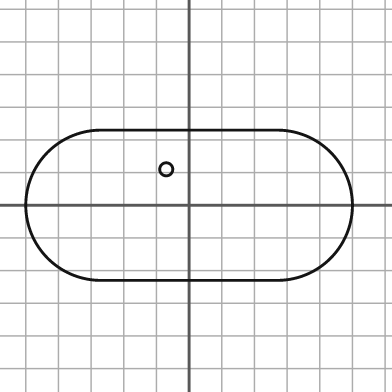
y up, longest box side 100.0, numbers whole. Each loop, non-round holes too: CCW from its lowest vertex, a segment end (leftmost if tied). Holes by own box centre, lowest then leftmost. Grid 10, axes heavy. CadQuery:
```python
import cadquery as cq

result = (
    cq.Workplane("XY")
    .moveTo(-27.0, -23.0)
    .lineTo(27.0, -23.0)
    .threePointArc((50.0, 0.0), (27.0, 23.0))
    .lineTo(-27.0, 23.0)
    .threePointArc((-50.0, 0.0), (-27.0, -23.0))
    .close()
    .moveTo(-7.0, 11.0)
    .circle(2.0)
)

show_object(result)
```